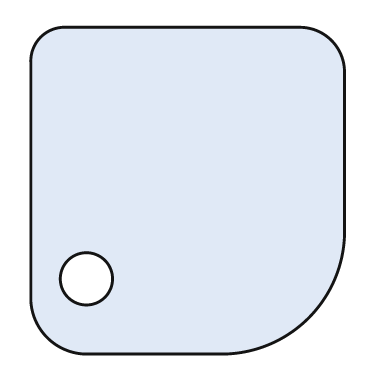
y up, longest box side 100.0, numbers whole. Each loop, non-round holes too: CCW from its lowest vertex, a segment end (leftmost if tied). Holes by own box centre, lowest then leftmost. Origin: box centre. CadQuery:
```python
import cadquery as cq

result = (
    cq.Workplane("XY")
    .moveTo(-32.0, -50.0)
    .lineTo(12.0, -50.0)
    .threePointArc((37.0, -39.0), (48.0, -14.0))
    .lineTo(48.0, 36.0)
    .threePointArc((44.0, 46.0), (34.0, 50.0))
    .lineTo(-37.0, 50.0)
    .threePointArc((-45.0, 47.0), (-48.0, 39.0))
    .lineTo(-48.0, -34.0)
    .threePointArc((-43.0, -45.0), (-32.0, -50.0))
    .close()
    .moveTo(-31.0, -27.0)
    .circle(8.0)
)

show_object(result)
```